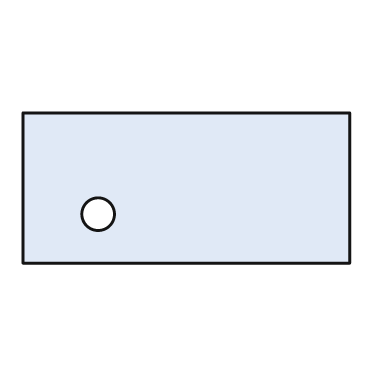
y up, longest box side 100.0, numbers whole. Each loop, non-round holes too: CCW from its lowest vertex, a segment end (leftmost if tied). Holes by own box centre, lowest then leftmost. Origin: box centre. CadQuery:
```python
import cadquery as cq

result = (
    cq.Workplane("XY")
    .moveTo(-50.0, -23.0)
    .lineTo(50.0, -23.0)
    .lineTo(50.0, 23.0)
    .lineTo(-50.0, 23.0)
    .close()
    .moveTo(-27.0, -8.0)
    .circle(5.0)
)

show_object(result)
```